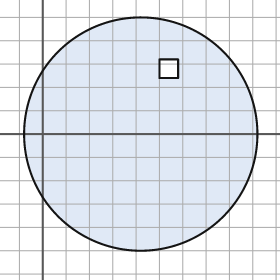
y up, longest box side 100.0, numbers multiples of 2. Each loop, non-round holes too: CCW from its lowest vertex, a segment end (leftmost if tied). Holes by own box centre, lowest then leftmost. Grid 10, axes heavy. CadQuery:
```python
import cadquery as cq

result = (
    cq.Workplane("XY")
    .moveTo(42.0, 0.0)
    .circle(50.0)
    .moveTo(50.0, 24.0)
    .lineTo(58.0, 24.0)
    .lineTo(58.0, 32.0)
    .lineTo(50.0, 32.0)
    .close()
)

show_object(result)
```